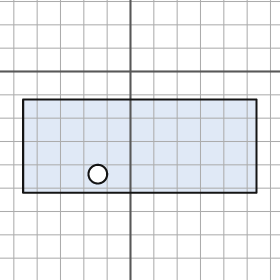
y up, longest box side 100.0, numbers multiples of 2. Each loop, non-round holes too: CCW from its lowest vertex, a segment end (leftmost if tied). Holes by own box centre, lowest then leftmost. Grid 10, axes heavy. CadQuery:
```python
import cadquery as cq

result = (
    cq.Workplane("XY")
    .moveTo(-46.0, -52.0)
    .lineTo(54.0, -52.0)
    .lineTo(54.0, -12.0)
    .lineTo(-46.0, -12.0)
    .close()
    .moveTo(-14.0, -44.0)
    .circle(4.0)
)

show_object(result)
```